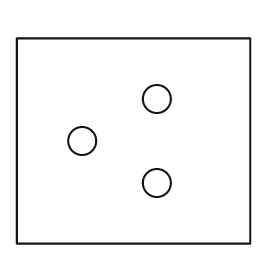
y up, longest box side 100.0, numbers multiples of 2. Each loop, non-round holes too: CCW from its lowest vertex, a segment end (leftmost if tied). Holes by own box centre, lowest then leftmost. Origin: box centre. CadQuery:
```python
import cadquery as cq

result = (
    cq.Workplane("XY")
    .moveTo(-50.0, -44.0)
    .lineTo(50.0, -44.0)
    .lineTo(50.0, 44.0)
    .lineTo(-50.0, 44.0)
    .close()
    .moveTo(10.0, -18.0)
    .circle(6.0)
    .moveTo(-22.0, 0.0)
    .circle(6.0)
    .moveTo(10.0, 18.0)
    .circle(6.0)
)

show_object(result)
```